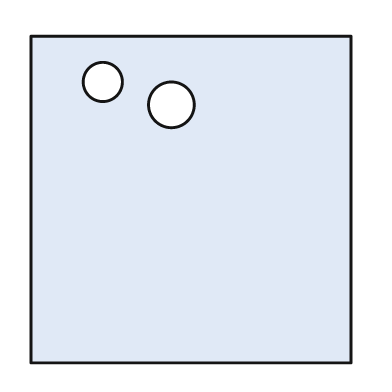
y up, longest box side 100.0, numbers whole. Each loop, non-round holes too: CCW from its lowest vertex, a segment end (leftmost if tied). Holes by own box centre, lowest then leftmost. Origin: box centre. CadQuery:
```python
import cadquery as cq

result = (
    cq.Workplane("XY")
    .moveTo(-49.0, -50.0)
    .lineTo(49.0, -50.0)
    .lineTo(49.0, 50.0)
    .lineTo(-49.0, 50.0)
    .close()
    .moveTo(-6.0, 29.0)
    .circle(7.0)
    .moveTo(-27.0, 36.0)
    .circle(6.0)
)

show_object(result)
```